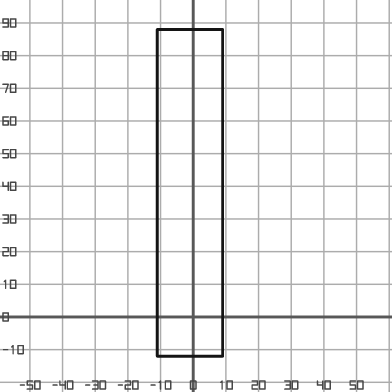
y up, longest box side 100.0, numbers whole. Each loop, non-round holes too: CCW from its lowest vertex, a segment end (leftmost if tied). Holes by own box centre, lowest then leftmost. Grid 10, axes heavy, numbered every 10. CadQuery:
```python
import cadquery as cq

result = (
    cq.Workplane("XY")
    .moveTo(-11.0, -12.0)
    .lineTo(9.0, -12.0)
    .lineTo(9.0, 88.0)
    .lineTo(-11.0, 88.0)
    .close()
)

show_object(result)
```